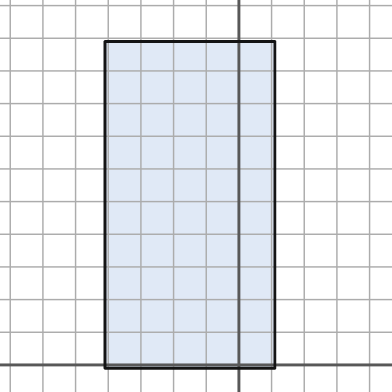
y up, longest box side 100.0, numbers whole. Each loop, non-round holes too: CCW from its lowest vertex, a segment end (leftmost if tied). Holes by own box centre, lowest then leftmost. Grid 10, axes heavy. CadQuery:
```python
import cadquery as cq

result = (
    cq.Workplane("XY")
    .moveTo(-41.0, -1.0)
    .lineTo(11.0, -1.0)
    .lineTo(11.0, 99.0)
    .lineTo(-41.0, 99.0)
    .close()
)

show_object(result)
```